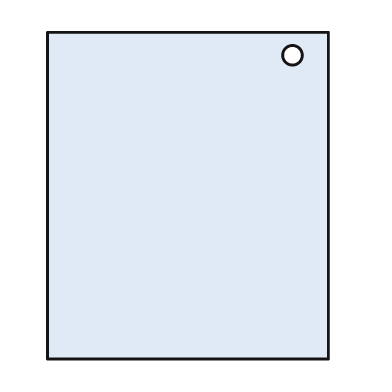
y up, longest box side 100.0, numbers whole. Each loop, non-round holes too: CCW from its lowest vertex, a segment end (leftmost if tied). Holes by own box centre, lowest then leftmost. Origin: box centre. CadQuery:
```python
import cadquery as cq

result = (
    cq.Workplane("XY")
    .moveTo(-43.0, -50.0)
    .lineTo(43.0, -50.0)
    .lineTo(43.0, 50.0)
    .lineTo(-43.0, 50.0)
    .close()
    .moveTo(32.0, 43.0)
    .circle(3.0)
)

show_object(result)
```